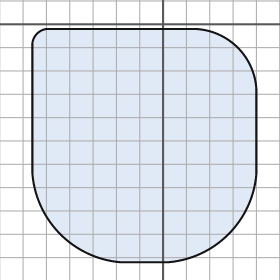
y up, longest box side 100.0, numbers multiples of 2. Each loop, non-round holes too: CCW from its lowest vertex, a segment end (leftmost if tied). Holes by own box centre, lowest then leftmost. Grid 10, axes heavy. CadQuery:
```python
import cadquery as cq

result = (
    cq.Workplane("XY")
    .moveTo(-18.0, -102.0)
    .lineTo(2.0, -102.0)
    .threePointArc((28.0, -90.0), (40.0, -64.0))
    .lineTo(40.0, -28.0)
    .threePointArc((32.0, -10.0), (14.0, -2.0))
    .lineTo(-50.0, -2.0)
    .threePointArc((-54.0, -4.0), (-56.0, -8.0))
    .lineTo(-56.0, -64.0)
    .threePointArc((-44.0, -90.0), (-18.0, -102.0))
    .close()
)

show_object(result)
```